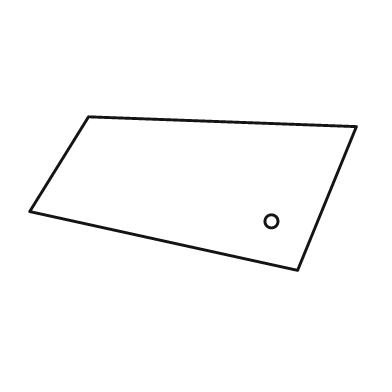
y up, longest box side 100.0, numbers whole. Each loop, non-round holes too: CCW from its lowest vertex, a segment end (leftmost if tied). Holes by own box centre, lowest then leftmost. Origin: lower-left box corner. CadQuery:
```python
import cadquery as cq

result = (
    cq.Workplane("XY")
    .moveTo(82.0, 0.0)
    .lineTo(100.0, 44.0)
    .lineTo(18.0, 47.0)
    .lineTo(0.0, 18.0)
    .close()
    .moveTo(74.0, 15.0)
    .circle(2.0)
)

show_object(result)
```